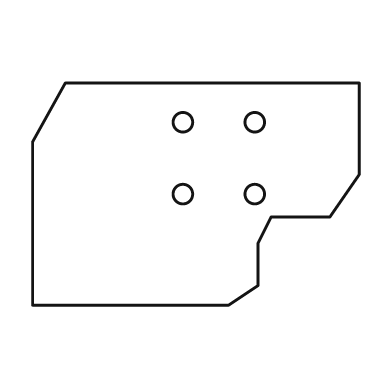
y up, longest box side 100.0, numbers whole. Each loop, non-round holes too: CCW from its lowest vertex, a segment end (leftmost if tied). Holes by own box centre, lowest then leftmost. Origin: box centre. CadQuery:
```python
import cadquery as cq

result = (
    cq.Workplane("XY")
    .moveTo(-50.0, -34.0)
    .lineTo(10.0, -34.0)
    .lineTo(19.0, -28.0)
    .lineTo(19.0, -15.0)
    .lineTo(23.0, -7.0)
    .lineTo(41.0, -7.0)
    .lineTo(50.0, 6.0)
    .lineTo(50.0, 34.0)
    .lineTo(-40.0, 34.0)
    .lineTo(-50.0, 16.0)
    .close()
    .moveTo(-4.0, 0.0)
    .circle(3.0)
    .moveTo(18.0, 0.0)
    .circle(3.0)
    .moveTo(-4.0, 22.0)
    .circle(3.0)
    .moveTo(18.0, 22.0)
    .circle(3.0)
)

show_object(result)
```